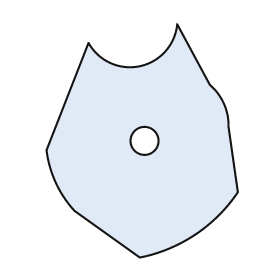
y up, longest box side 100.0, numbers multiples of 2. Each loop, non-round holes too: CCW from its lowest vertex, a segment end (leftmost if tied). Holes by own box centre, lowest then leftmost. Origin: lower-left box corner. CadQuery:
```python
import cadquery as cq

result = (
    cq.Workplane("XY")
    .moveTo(40.0, 0.0)
    .threePointArc((64.0, 10.0), (82.0, 28.0))
    .lineTo(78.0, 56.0)
    .threePointArc((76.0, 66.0), (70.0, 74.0))
    .lineTo(56.0, 100.0)
    .threePointArc((40.0, 82.0), (18.0, 92.0))
    .lineTo(0.0, 46.0)
    .threePointArc((4.0, 32.0), (12.0, 20.0))
    .close()
    .moveTo(42.0, 50.0)
    .circle(6.0)
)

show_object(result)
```